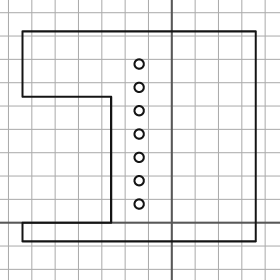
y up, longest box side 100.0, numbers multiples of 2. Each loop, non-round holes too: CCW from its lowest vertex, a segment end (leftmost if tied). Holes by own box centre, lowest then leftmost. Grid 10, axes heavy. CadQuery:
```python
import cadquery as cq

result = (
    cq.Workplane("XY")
    .moveTo(-64.0, -8.0)
    .lineTo(36.0, -8.0)
    .lineTo(36.0, 82.0)
    .lineTo(-64.0, 82.0)
    .lineTo(-64.0, 54.0)
    .lineTo(-26.0, 54.0)
    .lineTo(-26.0, 0.0)
    .lineTo(-64.0, 0.0)
    .close()
    .moveTo(-14.0, 8.0)
    .circle(2.0)
    .moveTo(-14.0, 18.0)
    .circle(2.0)
    .moveTo(-14.0, 28.0)
    .circle(2.0)
    .moveTo(-14.0, 38.0)
    .circle(2.0)
    .moveTo(-14.0, 48.0)
    .circle(2.0)
    .moveTo(-14.0, 58.0)
    .circle(2.0)
    .moveTo(-14.0, 68.0)
    .circle(2.0)
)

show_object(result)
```